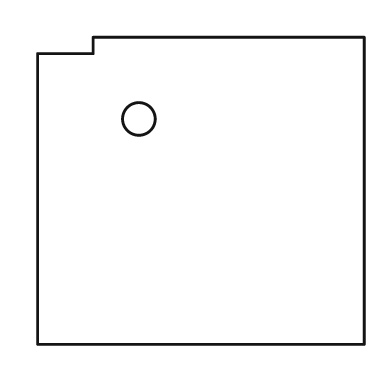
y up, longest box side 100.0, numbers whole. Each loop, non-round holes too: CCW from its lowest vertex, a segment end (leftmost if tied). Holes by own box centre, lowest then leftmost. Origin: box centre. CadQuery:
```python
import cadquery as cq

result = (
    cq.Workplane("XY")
    .moveTo(-50.0, -47.0)
    .lineTo(50.0, -47.0)
    .lineTo(50.0, 47.0)
    .lineTo(-33.0, 47.0)
    .lineTo(-33.0, 42.0)
    .lineTo(-50.0, 42.0)
    .close()
    .moveTo(-19.0, 22.0)
    .circle(5.0)
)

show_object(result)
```